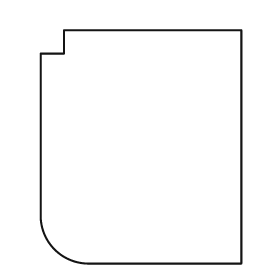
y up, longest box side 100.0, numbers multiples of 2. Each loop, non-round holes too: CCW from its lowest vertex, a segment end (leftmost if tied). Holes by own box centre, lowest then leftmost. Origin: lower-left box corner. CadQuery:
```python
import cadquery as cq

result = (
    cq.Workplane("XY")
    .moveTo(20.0, 0.0)
    .lineTo(86.0, 0.0)
    .lineTo(86.0, 100.0)
    .lineTo(10.0, 100.0)
    .lineTo(10.0, 90.0)
    .lineTo(0.0, 90.0)
    .lineTo(0.0, 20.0)
    .threePointArc((6.0, 6.0), (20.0, 0.0))
    .close()
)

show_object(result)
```